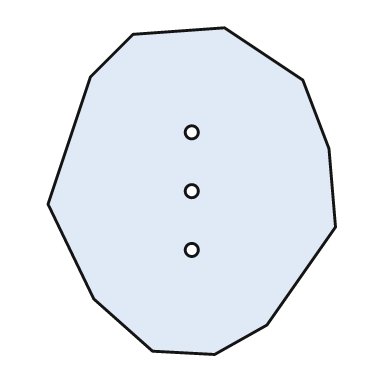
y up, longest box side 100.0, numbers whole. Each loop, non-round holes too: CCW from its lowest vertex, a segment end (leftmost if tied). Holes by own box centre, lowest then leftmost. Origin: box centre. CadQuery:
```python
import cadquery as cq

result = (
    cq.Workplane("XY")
    .moveTo(7.0, -50.0)
    .lineTo(23.0, -41.0)
    .lineTo(44.0, -11.0)
    .lineTo(42.0, 13.0)
    .lineTo(34.0, 34.0)
    .lineTo(10.0, 50.0)
    .lineTo(-18.0, 48.0)
    .lineTo(-31.0, 35.0)
    .lineTo(-44.0, -4.0)
    .lineTo(-30.0, -33.0)
    .lineTo(-12.0, -49.0)
    .close()
    .moveTo(0.0, -18.0)
    .circle(2.0)
    .moveTo(0.0, 0.0)
    .circle(2.0)
    .moveTo(0.0, 18.0)
    .circle(2.0)
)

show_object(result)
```